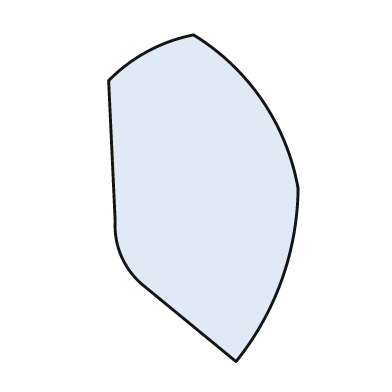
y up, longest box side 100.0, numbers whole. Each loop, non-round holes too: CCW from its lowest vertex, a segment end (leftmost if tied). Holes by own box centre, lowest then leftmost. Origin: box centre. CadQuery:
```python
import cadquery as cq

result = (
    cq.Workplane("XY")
    .moveTo(10.0, -50.0)
    .threePointArc((24.0, -25.0), (29.0, 3.0))
    .threePointArc((18.0, 30.0), (-3.0, 50.0))
    .threePointArc((-17.0, 45.0), (-29.0, 36.0))
    .lineTo(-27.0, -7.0)
    .threePointArc((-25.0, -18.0), (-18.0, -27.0))
    .close()
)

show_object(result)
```